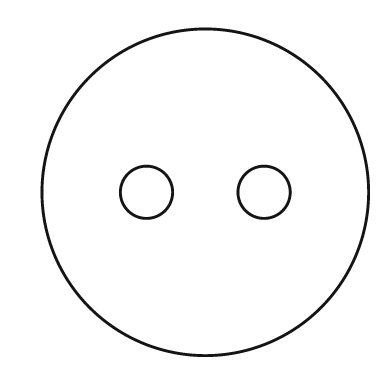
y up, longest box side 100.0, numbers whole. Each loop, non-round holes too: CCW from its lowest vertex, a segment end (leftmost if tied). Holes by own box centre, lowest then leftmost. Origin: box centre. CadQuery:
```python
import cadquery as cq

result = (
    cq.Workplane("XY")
    .moveTo(0.0, 0.0)
    .circle(50.0)
    .moveTo(-18.0, 0.0)
    .circle(8.0)
    .moveTo(18.0, 0.0)
    .circle(8.0)
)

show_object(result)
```